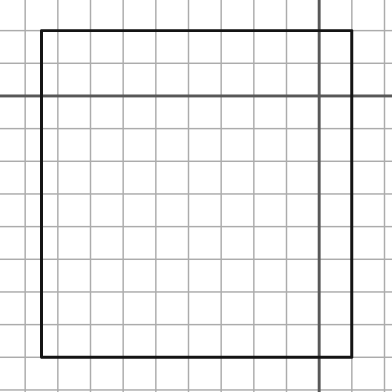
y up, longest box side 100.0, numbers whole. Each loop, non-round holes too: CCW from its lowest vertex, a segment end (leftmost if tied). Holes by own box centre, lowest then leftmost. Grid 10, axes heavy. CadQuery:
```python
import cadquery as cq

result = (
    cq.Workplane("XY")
    .moveTo(-85.0, -80.0)
    .lineTo(10.0, -80.0)
    .lineTo(10.0, 20.0)
    .lineTo(-85.0, 20.0)
    .close()
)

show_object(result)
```